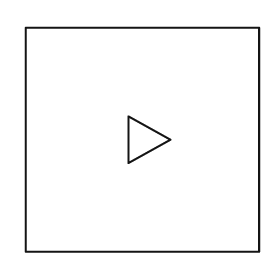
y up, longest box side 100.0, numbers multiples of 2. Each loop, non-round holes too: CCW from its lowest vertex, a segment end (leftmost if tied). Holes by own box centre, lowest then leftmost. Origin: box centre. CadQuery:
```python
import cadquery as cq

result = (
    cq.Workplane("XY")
    .moveTo(-50.0, -48.0)
    .lineTo(50.0, -48.0)
    .lineTo(50.0, 48.0)
    .lineTo(-50.0, 48.0)
    .close()
    .moveTo(-6.0, -10.0)
    .lineTo(12.0, 0.0)
    .lineTo(-6.0, 10.0)
    .close()
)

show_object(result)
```